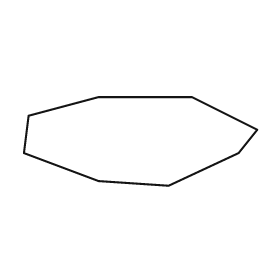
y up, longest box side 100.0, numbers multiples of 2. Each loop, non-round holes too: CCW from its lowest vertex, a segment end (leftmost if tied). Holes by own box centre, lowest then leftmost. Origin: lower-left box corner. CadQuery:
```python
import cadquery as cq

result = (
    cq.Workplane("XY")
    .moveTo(62.0, 0.0)
    .lineTo(92.0, 14.0)
    .lineTo(100.0, 24.0)
    .lineTo(72.0, 38.0)
    .lineTo(32.0, 38.0)
    .lineTo(2.0, 30.0)
    .lineTo(0.0, 14.0)
    .lineTo(32.0, 2.0)
    .close()
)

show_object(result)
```